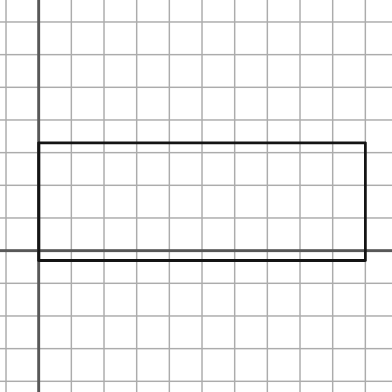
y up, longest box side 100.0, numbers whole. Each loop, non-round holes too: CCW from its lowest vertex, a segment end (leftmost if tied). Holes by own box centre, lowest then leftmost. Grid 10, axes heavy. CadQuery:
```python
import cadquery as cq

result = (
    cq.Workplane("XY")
    .moveTo(0.0, -3.0)
    .lineTo(100.0, -3.0)
    .lineTo(100.0, 33.0)
    .lineTo(0.0, 33.0)
    .close()
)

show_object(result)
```